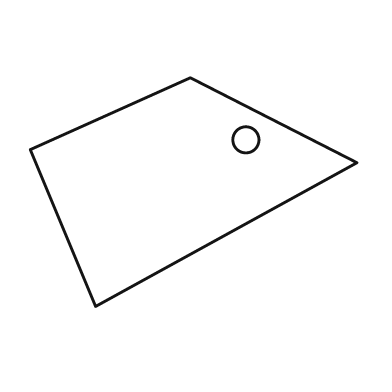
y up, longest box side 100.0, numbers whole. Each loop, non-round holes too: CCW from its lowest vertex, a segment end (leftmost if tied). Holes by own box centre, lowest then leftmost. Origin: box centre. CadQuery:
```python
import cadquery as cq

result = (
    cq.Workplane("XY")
    .moveTo(-30.0, -35.0)
    .lineTo(50.0, 9.0)
    .lineTo(-1.0, 35.0)
    .lineTo(-50.0, 13.0)
    .close()
    .moveTo(16.0, 16.0)
    .circle(4.0)
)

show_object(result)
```